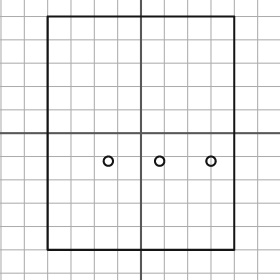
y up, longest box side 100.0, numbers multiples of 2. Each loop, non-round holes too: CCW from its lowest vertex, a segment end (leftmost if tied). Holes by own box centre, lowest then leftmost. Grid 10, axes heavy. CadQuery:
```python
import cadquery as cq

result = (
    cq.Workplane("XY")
    .moveTo(-40.0, -50.0)
    .lineTo(40.0, -50.0)
    .lineTo(40.0, 50.0)
    .lineTo(-40.0, 50.0)
    .close()
    .moveTo(-14.0, -12.0)
    .circle(2.0)
    .moveTo(8.0, -12.0)
    .circle(2.0)
    .moveTo(30.0, -12.0)
    .circle(2.0)
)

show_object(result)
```